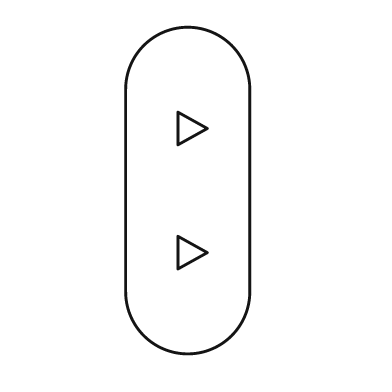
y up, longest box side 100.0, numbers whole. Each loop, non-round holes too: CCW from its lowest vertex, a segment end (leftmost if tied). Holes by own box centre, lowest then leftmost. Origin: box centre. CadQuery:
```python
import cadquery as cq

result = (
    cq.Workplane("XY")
    .moveTo(-19.0, -31.0)
    .threePointArc((0.0, -50.0), (19.0, -31.0))
    .lineTo(19.0, 31.0)
    .threePointArc((0.0, 50.0), (-19.0, 31.0))
    .close()
    .moveTo(-3.0, -24.0)
    .lineTo(6.0, -19.0)
    .lineTo(-3.0, -14.0)
    .close()
    .moveTo(-3.0, 14.0)
    .lineTo(6.0, 19.0)
    .lineTo(-3.0, 24.0)
    .close()
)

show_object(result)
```